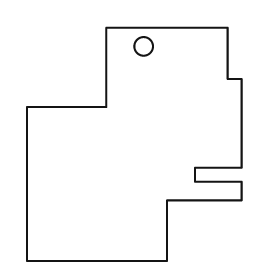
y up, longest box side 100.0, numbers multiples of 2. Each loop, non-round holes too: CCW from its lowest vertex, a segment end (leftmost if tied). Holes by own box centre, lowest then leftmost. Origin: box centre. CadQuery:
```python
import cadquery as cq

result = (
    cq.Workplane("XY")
    .moveTo(-46.0, -50.0)
    .lineTo(14.0, -50.0)
    .lineTo(14.0, -24.0)
    .lineTo(46.0, -24.0)
    .lineTo(46.0, -16.0)
    .lineTo(26.0, -16.0)
    .lineTo(26.0, -10.0)
    .lineTo(46.0, -10.0)
    .lineTo(46.0, 28.0)
    .lineTo(40.0, 28.0)
    .lineTo(40.0, 50.0)
    .lineTo(-12.0, 50.0)
    .lineTo(-12.0, 16.0)
    .lineTo(-46.0, 16.0)
    .close()
    .moveTo(4.0, 42.0)
    .circle(4.0)
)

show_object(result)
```